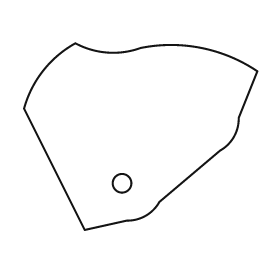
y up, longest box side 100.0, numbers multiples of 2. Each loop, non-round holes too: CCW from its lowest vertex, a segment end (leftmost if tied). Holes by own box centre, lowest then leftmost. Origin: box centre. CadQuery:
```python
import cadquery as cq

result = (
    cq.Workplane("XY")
    .moveTo(-24.0, -40.0)
    .lineTo(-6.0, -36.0)
    .threePointArc((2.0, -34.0), (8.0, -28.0))
    .lineTo(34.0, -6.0)
    .threePointArc((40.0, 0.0), (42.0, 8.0))
    .lineTo(50.0, 28.0)
    .threePointArc((26.0, 38.0), (0.0, 38.0))
    .threePointArc((-14.0, 36.0), (-28.0, 40.0))
    .threePointArc((-42.0, 28.0), (-50.0, 12.0))
    .close()
    .moveTo(-8.0, -20.0)
    .circle(4.0)
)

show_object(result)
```